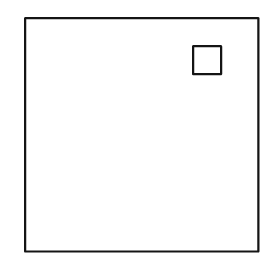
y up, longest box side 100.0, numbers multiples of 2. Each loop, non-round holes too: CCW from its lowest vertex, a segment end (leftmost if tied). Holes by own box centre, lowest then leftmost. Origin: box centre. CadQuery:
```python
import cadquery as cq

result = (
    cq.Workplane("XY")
    .moveTo(-50.0, -50.0)
    .lineTo(50.0, -50.0)
    .lineTo(50.0, 50.0)
    .lineTo(-50.0, 50.0)
    .close()
    .moveTo(22.0, 26.0)
    .lineTo(34.0, 26.0)
    .lineTo(34.0, 38.0)
    .lineTo(22.0, 38.0)
    .close()
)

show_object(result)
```